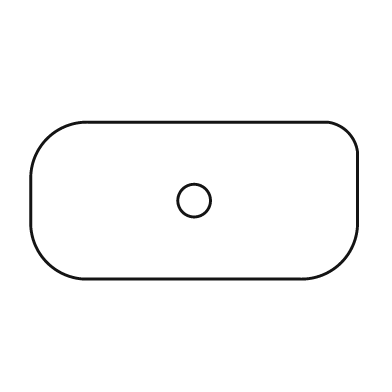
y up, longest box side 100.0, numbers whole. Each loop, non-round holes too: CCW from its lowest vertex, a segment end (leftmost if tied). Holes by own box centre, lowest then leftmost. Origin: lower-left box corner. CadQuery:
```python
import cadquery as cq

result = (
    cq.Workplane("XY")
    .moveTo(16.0, 0.0)
    .lineTo(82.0, 0.0)
    .threePointArc((95.0, 5.0), (100.0, 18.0))
    .lineTo(100.0, 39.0)
    .threePointArc((97.0, 45.0), (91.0, 48.0))
    .lineTo(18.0, 48.0)
    .threePointArc((5.0, 43.0), (0.0, 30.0))
    .lineTo(0.0, 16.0)
    .threePointArc((5.0, 5.0), (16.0, 0.0))
    .close()
    .moveTo(50.0, 24.0)
    .circle(5.0)
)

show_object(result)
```